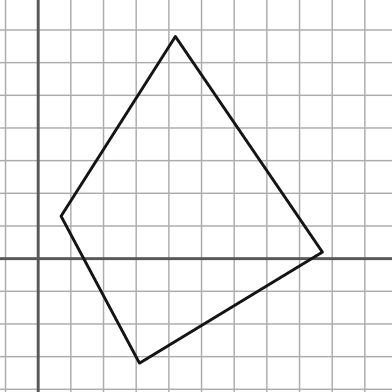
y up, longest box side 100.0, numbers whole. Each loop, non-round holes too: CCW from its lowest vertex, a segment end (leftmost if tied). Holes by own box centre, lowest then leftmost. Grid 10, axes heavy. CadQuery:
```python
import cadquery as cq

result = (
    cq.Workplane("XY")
    .moveTo(31.0, -32.0)
    .lineTo(87.0, 2.0)
    .lineTo(42.0, 68.0)
    .lineTo(7.0, 13.0)
    .close()
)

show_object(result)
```